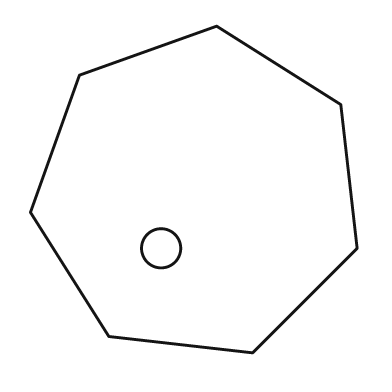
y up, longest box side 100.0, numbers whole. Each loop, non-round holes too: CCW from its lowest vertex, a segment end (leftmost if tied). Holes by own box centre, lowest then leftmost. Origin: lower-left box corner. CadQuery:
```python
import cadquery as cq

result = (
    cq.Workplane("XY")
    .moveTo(68.0, 0.0)
    .lineTo(100.0, 32.0)
    .lineTo(95.0, 76.0)
    .lineTo(57.0, 100.0)
    .lineTo(15.0, 85.0)
    .lineTo(0.0, 43.0)
    .lineTo(24.0, 5.0)
    .close()
    .moveTo(40.0, 32.0)
    .circle(6.0)
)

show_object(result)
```